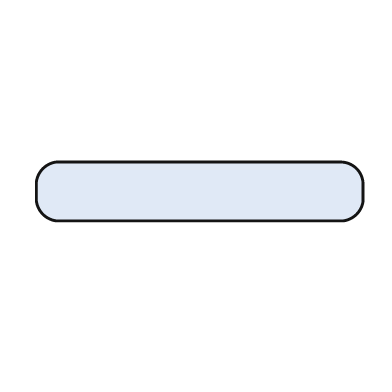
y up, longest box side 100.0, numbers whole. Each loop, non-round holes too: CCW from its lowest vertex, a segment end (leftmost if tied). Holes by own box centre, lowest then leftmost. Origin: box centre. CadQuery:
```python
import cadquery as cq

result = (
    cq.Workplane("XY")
    .moveTo(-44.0, -9.0)
    .lineTo(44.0, -9.0)
    .threePointArc((48.0, -7.0), (50.0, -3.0))
    .lineTo(50.0, 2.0)
    .threePointArc((48.0, 7.0), (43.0, 9.0))
    .lineTo(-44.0, 9.0)
    .threePointArc((-48.0, 7.0), (-50.0, 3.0))
    .lineTo(-50.0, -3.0)
    .threePointArc((-48.0, -7.0), (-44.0, -9.0))
    .close()
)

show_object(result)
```